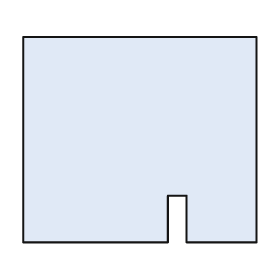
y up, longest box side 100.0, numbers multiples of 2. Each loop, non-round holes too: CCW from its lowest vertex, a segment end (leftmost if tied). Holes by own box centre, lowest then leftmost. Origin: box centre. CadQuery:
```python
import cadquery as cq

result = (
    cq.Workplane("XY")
    .moveTo(-50.0, -44.0)
    .lineTo(12.0, -44.0)
    .lineTo(12.0, -24.0)
    .lineTo(20.0, -24.0)
    .lineTo(20.0, -44.0)
    .lineTo(50.0, -44.0)
    .lineTo(50.0, 44.0)
    .lineTo(-50.0, 44.0)
    .close()
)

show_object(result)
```